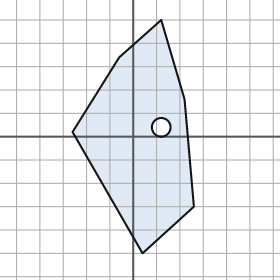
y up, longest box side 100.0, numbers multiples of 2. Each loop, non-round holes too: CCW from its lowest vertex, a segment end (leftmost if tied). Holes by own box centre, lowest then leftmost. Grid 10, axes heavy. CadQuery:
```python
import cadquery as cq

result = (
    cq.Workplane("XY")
    .moveTo(4.0, -50.0)
    .lineTo(26.0, -30.0)
    .lineTo(22.0, 16.0)
    .lineTo(12.0, 50.0)
    .lineTo(-6.0, 34.0)
    .lineTo(-26.0, 2.0)
    .close()
    .moveTo(12.0, 4.0)
    .circle(4.0)
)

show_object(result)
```